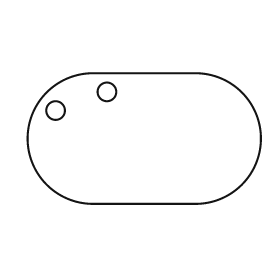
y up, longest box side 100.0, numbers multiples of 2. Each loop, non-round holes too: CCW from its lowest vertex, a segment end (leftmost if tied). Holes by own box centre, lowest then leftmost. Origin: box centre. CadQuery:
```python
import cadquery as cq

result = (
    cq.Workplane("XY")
    .moveTo(-22.0, -28.0)
    .lineTo(22.0, -28.0)
    .threePointArc((50.0, 0.0), (22.0, 28.0))
    .lineTo(-22.0, 28.0)
    .threePointArc((-50.0, 0.0), (-22.0, -28.0))
    .close()
    .moveTo(-38.0, 12.0)
    .circle(4.0)
    .moveTo(-16.0, 20.0)
    .circle(4.0)
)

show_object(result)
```